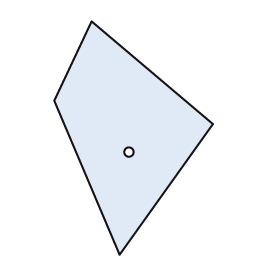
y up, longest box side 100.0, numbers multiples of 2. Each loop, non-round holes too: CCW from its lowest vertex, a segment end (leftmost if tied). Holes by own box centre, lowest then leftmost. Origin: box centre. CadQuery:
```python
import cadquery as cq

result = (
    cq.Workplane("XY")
    .moveTo(-6.0, -50.0)
    .lineTo(34.0, 6.0)
    .lineTo(-18.0, 50.0)
    .lineTo(-34.0, 16.0)
    .close()
    .moveTo(-2.0, -6.0)
    .circle(2.0)
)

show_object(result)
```